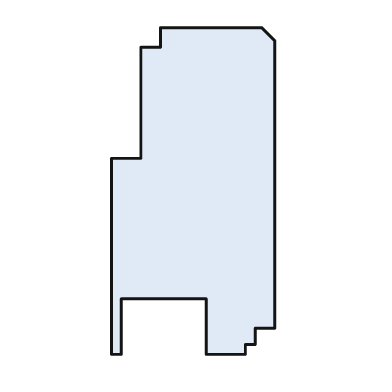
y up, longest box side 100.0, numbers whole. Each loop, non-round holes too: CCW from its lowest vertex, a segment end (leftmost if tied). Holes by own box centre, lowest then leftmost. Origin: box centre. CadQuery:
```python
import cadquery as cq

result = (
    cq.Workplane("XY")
    .moveTo(-25.0, -50.0)
    .lineTo(-22.0, -50.0)
    .lineTo(-22.0, -33.0)
    .lineTo(4.0, -33.0)
    .lineTo(4.0, -50.0)
    .lineTo(16.0, -50.0)
    .lineTo(16.0, -47.0)
    .lineTo(19.0, -47.0)
    .lineTo(19.0, -42.0)
    .lineTo(25.0, -42.0)
    .lineTo(25.0, 46.0)
    .lineTo(21.0, 50.0)
    .lineTo(-10.0, 50.0)
    .lineTo(-10.0, 44.0)
    .lineTo(-16.0, 44.0)
    .lineTo(-16.0, 10.0)
    .lineTo(-25.0, 10.0)
    .close()
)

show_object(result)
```